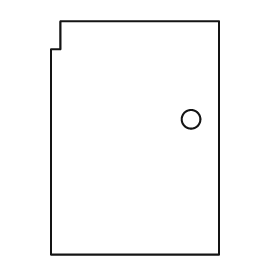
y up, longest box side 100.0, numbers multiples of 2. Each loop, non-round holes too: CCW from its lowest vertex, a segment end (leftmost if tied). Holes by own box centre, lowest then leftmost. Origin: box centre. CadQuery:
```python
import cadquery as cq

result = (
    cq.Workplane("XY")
    .moveTo(-36.0, -50.0)
    .lineTo(36.0, -50.0)
    .lineTo(36.0, 50.0)
    .lineTo(-32.0, 50.0)
    .lineTo(-32.0, 38.0)
    .lineTo(-36.0, 38.0)
    .close()
    .moveTo(24.0, 8.0)
    .circle(4.0)
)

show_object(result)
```